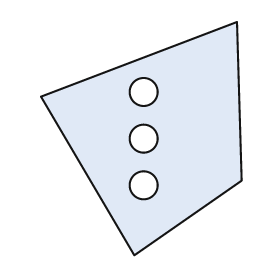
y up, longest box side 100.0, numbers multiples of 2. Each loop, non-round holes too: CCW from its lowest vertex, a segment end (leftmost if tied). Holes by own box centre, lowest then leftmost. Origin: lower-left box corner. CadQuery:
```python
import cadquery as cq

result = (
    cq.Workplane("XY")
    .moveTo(40.0, 0.0)
    .lineTo(86.0, 32.0)
    .lineTo(84.0, 100.0)
    .lineTo(0.0, 68.0)
    .close()
    .moveTo(44.0, 30.0)
    .circle(6.0)
    .moveTo(44.0, 50.0)
    .circle(6.0)
    .moveTo(44.0, 70.0)
    .circle(6.0)
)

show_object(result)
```